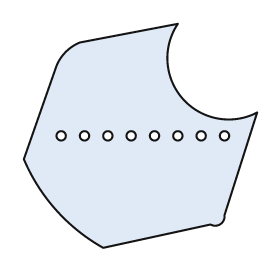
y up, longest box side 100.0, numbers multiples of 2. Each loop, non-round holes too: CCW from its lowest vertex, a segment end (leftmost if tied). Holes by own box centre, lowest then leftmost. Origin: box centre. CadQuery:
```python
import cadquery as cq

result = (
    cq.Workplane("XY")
    .moveTo(-16.0, -48.0)
    .lineTo(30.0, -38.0)
    .threePointArc((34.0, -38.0), (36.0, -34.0))
    .lineTo(50.0, 10.0)
    .threePointArc((18.0, 16.0), (16.0, 48.0))
    .lineTo(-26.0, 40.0)
    .threePointArc((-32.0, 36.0), (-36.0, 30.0))
    .lineTo(-50.0, -10.0)
    .threePointArc((-36.0, -32.0), (-16.0, -48.0))
    .close()
    .moveTo(-34.0, 0.0)
    .circle(2.0)
    .moveTo(-24.0, 0.0)
    .circle(2.0)
    .moveTo(-14.0, 0.0)
    .circle(2.0)
    .moveTo(-4.0, 0.0)
    .circle(2.0)
    .moveTo(6.0, 0.0)
    .circle(2.0)
    .moveTo(16.0, 0.0)
    .circle(2.0)
    .moveTo(26.0, 0.0)
    .circle(2.0)
    .moveTo(36.0, 0.0)
    .circle(2.0)
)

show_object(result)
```